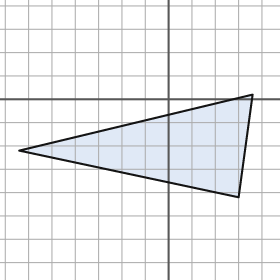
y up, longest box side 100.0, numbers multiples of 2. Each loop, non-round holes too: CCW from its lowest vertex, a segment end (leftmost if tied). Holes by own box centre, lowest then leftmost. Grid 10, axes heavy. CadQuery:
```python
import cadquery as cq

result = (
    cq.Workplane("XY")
    .moveTo(30.0, -42.0)
    .lineTo(36.0, 2.0)
    .lineTo(-64.0, -22.0)
    .close()
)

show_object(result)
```